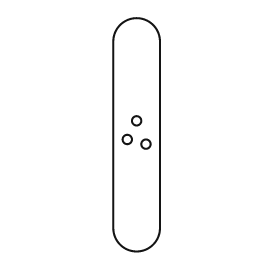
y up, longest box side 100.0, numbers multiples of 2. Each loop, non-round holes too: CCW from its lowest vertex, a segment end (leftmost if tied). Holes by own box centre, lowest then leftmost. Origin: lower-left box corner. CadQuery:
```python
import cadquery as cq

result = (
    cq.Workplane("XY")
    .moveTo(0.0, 10.0)
    .threePointArc((10.0, 0.0), (20.0, 10.0))
    .lineTo(20.0, 90.0)
    .threePointArc((10.0, 100.0), (0.0, 90.0))
    .close()
    .moveTo(14.0, 46.0)
    .circle(2.0)
    .moveTo(6.0, 48.0)
    .circle(2.0)
    .moveTo(10.0, 56.0)
    .circle(2.0)
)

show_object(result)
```